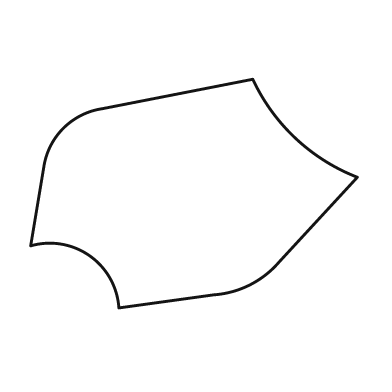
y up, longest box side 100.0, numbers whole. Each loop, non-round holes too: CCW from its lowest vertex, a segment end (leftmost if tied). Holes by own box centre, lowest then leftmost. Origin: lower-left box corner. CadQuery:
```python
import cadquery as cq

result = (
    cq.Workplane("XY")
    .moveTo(27.0, 0.0)
    .lineTo(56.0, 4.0)
    .threePointArc((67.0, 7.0), (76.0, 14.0))
    .lineTo(100.0, 40.0)
    .threePointArc((81.0, 52.0), (68.0, 70.0))
    .lineTo(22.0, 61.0)
    .threePointArc((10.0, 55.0), (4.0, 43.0))
    .lineTo(0.0, 19.0)
    .threePointArc((18.0, 16.0), (27.0, 0.0))
    .close()
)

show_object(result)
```